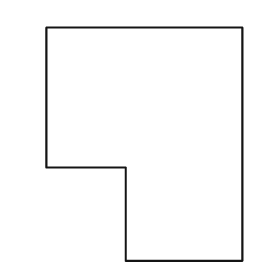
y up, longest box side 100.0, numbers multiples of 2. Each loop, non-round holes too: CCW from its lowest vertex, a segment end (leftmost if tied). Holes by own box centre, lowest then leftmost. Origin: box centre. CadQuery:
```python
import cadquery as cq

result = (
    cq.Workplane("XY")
    .moveTo(-8.0, -50.0)
    .lineTo(42.0, -50.0)
    .lineTo(42.0, 50.0)
    .lineTo(-42.0, 50.0)
    .lineTo(-42.0, -10.0)
    .lineTo(-8.0, -10.0)
    .close()
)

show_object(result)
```